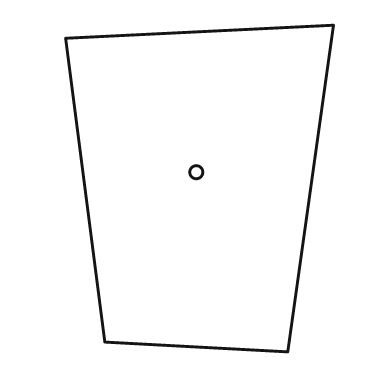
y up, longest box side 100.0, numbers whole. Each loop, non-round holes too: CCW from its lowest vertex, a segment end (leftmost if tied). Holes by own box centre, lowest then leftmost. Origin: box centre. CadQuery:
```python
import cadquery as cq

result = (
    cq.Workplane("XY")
    .moveTo(27.0, -50.0)
    .lineTo(41.0, 50.0)
    .lineTo(-41.0, 46.0)
    .lineTo(-29.0, -47.0)
    .close()
    .moveTo(-1.0, 5.0)
    .circle(2.0)
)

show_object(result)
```